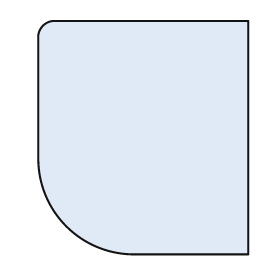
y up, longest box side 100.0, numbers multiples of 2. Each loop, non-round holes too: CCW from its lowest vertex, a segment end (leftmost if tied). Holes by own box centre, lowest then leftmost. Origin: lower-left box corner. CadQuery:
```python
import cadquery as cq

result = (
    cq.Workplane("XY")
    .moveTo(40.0, 0.0)
    .lineTo(90.0, 0.0)
    .lineTo(90.0, 100.0)
    .lineTo(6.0, 100.0)
    .threePointArc((2.0, 98.0), (0.0, 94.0))
    .lineTo(0.0, 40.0)
    .threePointArc((12.0, 12.0), (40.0, 0.0))
    .close()
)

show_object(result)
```